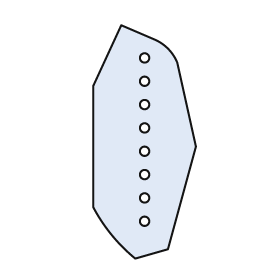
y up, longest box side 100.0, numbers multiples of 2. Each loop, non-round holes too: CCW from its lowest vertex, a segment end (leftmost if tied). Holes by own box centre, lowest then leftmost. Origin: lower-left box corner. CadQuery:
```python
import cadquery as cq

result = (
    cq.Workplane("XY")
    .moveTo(18.0, 0.0)
    .lineTo(32.0, 4.0)
    .lineTo(44.0, 48.0)
    .lineTo(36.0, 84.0)
    .threePointArc((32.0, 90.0), (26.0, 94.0))
    .lineTo(12.0, 100.0)
    .lineTo(0.0, 74.0)
    .lineTo(0.0, 22.0)
    .threePointArc((8.0, 10.0), (18.0, 0.0))
    .close()
    .moveTo(22.0, 16.0)
    .circle(2.0)
    .moveTo(22.0, 26.0)
    .circle(2.0)
    .moveTo(22.0, 36.0)
    .circle(2.0)
    .moveTo(22.0, 46.0)
    .circle(2.0)
    .moveTo(22.0, 56.0)
    .circle(2.0)
    .moveTo(22.0, 66.0)
    .circle(2.0)
    .moveTo(22.0, 76.0)
    .circle(2.0)
    .moveTo(22.0, 86.0)
    .circle(2.0)
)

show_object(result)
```